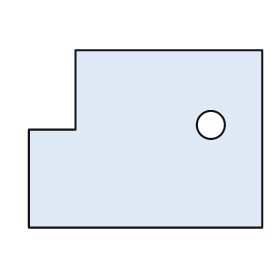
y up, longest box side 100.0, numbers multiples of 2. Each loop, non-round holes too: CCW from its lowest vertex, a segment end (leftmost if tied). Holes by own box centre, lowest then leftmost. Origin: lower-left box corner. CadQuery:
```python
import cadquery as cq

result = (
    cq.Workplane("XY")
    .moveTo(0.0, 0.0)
    .lineTo(100.0, 0.0)
    .lineTo(100.0, 76.0)
    .lineTo(20.0, 76.0)
    .lineTo(20.0, 42.0)
    .lineTo(0.0, 42.0)
    .close()
    .moveTo(78.0, 44.0)
    .circle(6.0)
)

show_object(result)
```